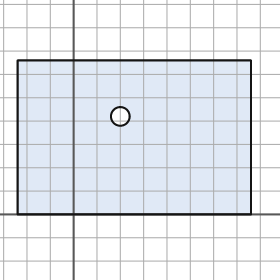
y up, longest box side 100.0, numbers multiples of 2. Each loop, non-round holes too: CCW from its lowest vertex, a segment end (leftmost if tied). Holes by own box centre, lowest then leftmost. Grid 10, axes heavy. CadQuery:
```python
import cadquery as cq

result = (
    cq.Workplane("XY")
    .moveTo(-24.0, 0.0)
    .lineTo(76.0, 0.0)
    .lineTo(76.0, 66.0)
    .lineTo(-24.0, 66.0)
    .close()
    .moveTo(20.0, 42.0)
    .circle(4.0)
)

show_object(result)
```